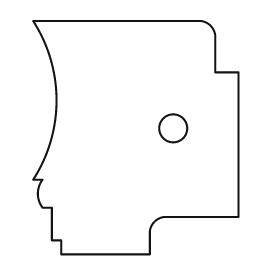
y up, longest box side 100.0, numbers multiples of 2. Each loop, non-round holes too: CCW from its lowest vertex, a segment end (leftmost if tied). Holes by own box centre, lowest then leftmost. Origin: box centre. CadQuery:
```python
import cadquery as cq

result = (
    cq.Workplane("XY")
    .moveTo(-32.0, -50.0)
    .lineTo(6.0, -50.0)
    .lineTo(6.0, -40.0)
    .threePointArc((8.0, -36.0), (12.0, -34.0))
    .lineTo(44.0, -34.0)
    .lineTo(44.0, 28.0)
    .lineTo(34.0, 28.0)
    .lineTo(34.0, 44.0)
    .threePointArc((32.0, 48.0), (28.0, 50.0))
    .lineTo(-44.0, 50.0)
    .threePointArc((-34.0, 16.0), (-44.0, -18.0))
    .lineTo(-40.0, -18.0)
    .threePointArc((-42.0, -24.0), (-40.0, -30.0))
    .lineTo(-36.0, -30.0)
    .lineTo(-36.0, -44.0)
    .lineTo(-32.0, -44.0)
    .close()
    .moveTo(16.0, 4.0)
    .circle(6.0)
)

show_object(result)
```